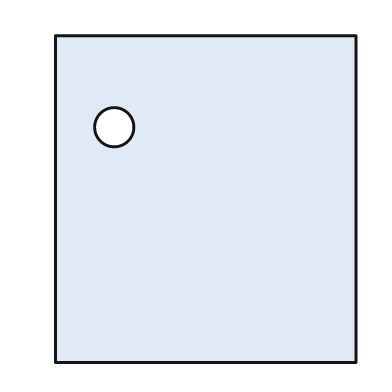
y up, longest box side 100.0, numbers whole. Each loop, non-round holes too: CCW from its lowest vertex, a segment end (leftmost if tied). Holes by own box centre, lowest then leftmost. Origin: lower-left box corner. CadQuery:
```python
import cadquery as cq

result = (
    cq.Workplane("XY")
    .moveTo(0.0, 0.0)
    .lineTo(92.0, 0.0)
    .lineTo(92.0, 100.0)
    .lineTo(0.0, 100.0)
    .close()
    .moveTo(18.0, 72.0)
    .circle(6.0)
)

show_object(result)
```